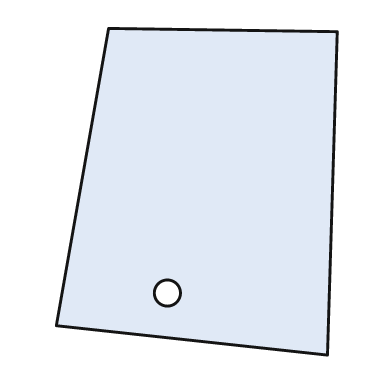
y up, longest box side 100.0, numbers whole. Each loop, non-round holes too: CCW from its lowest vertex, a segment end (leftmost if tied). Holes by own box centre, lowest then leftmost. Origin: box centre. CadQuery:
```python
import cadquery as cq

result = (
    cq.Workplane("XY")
    .moveTo(40.0, -50.0)
    .lineTo(43.0, 49.0)
    .lineTo(-27.0, 50.0)
    .lineTo(-43.0, -41.0)
    .close()
    .moveTo(-9.0, -31.0)
    .circle(4.0)
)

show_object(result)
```